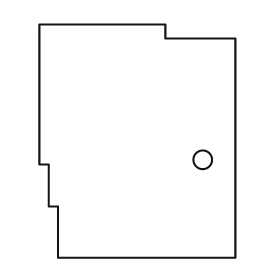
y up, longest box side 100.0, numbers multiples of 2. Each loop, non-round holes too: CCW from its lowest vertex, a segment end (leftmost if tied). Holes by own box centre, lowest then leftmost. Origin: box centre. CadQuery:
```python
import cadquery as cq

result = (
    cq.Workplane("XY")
    .moveTo(-34.0, -50.0)
    .lineTo(42.0, -50.0)
    .lineTo(42.0, 44.0)
    .lineTo(12.0, 44.0)
    .lineTo(12.0, 50.0)
    .lineTo(-42.0, 50.0)
    .lineTo(-42.0, -10.0)
    .lineTo(-38.0, -10.0)
    .lineTo(-38.0, -28.0)
    .lineTo(-34.0, -28.0)
    .close()
    .moveTo(28.0, -8.0)
    .circle(4.0)
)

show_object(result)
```